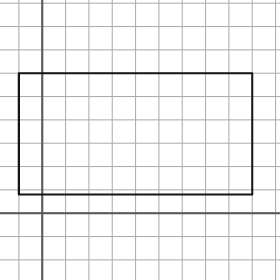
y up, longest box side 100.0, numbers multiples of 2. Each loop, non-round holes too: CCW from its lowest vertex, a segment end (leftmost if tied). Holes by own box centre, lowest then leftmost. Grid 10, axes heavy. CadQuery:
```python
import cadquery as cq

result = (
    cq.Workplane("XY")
    .moveTo(-10.0, 8.0)
    .lineTo(90.0, 8.0)
    .lineTo(90.0, 60.0)
    .lineTo(-10.0, 60.0)
    .close()
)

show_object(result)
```